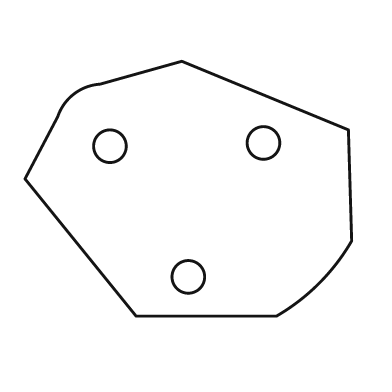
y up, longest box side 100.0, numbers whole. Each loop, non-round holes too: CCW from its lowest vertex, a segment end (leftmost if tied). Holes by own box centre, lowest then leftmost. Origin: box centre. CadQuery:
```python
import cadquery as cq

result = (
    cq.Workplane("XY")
    .moveTo(-16.0, -39.0)
    .lineTo(27.0, -39.0)
    .threePointArc((40.0, -29.0), (50.0, -16.0))
    .lineTo(49.0, 18.0)
    .lineTo(-2.0, 39.0)
    .lineTo(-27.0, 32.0)
    .threePointArc((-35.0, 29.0), (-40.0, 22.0))
    .lineTo(-50.0, 3.0)
    .close()
    .moveTo(0.0, -27.0)
    .circle(5.0)
    .moveTo(-24.0, 13.0)
    .circle(5.0)
    .moveTo(23.0, 14.0)
    .circle(5.0)
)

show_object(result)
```